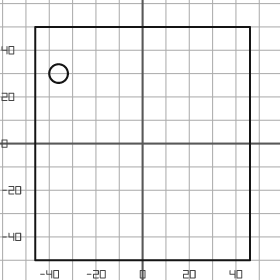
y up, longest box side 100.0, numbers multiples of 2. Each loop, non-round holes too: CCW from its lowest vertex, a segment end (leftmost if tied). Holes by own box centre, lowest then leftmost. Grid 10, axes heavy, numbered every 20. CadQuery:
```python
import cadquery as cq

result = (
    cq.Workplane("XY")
    .moveTo(-46.0, -50.0)
    .lineTo(46.0, -50.0)
    .lineTo(46.0, 50.0)
    .lineTo(-46.0, 50.0)
    .close()
    .moveTo(-36.0, 30.0)
    .circle(4.0)
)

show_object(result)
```